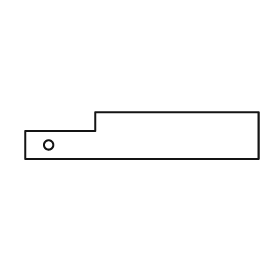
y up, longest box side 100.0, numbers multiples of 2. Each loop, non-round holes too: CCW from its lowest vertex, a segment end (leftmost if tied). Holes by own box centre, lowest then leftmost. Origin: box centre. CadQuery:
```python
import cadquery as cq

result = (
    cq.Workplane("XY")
    .moveTo(-50.0, -10.0)
    .lineTo(50.0, -10.0)
    .lineTo(50.0, 10.0)
    .lineTo(-20.0, 10.0)
    .lineTo(-20.0, 2.0)
    .lineTo(-50.0, 2.0)
    .close()
    .moveTo(-40.0, -4.0)
    .circle(2.0)
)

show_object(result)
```